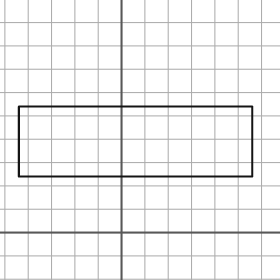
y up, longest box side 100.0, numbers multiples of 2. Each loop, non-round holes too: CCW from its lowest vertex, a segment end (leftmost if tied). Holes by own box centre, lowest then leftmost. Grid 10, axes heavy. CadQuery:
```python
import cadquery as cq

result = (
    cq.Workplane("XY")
    .moveTo(-44.0, 24.0)
    .lineTo(56.0, 24.0)
    .lineTo(56.0, 54.0)
    .lineTo(-44.0, 54.0)
    .close()
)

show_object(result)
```